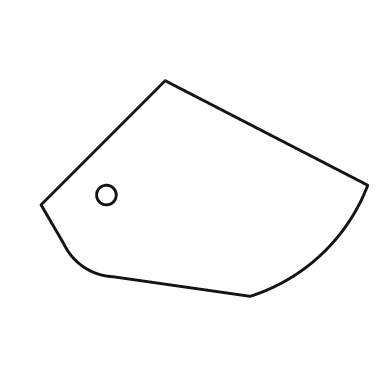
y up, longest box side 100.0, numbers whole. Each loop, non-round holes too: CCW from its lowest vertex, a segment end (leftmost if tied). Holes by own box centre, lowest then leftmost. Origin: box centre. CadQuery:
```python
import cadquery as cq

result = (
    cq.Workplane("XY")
    .moveTo(14.0, -33.0)
    .threePointArc((36.0, -20.0), (50.0, 1.0))
    .lineTo(-12.0, 33.0)
    .lineTo(-50.0, -5.0)
    .lineTo(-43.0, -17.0)
    .threePointArc((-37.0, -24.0), (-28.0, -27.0))
    .close()
    .moveTo(-30.0, -2.0)
    .circle(3.0)
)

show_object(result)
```